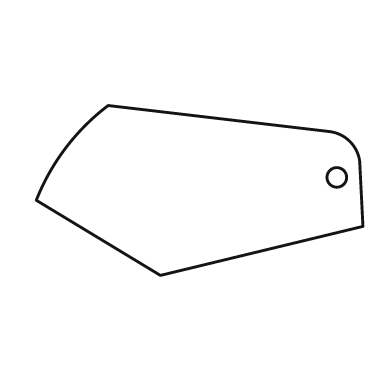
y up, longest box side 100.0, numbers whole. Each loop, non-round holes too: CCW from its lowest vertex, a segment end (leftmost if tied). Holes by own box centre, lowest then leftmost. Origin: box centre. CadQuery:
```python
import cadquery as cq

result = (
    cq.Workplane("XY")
    .moveTo(-12.0, -26.0)
    .lineTo(50.0, -11.0)
    .lineTo(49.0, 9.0)
    .threePointArc((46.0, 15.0), (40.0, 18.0))
    .lineTo(-28.0, 26.0)
    .threePointArc((-41.0, 13.0), (-50.0, -3.0))
    .close()
    .moveTo(42.0, 4.0)
    .circle(3.0)
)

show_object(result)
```